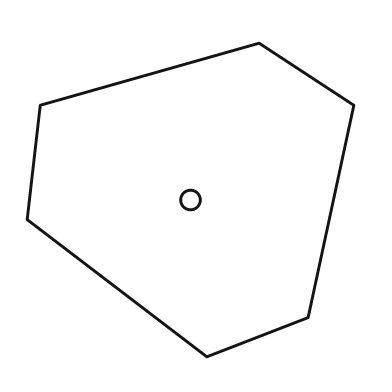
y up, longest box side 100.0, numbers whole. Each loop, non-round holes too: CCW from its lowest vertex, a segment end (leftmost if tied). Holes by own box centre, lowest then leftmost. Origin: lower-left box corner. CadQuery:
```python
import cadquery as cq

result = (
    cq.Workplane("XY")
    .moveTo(55.0, 0.0)
    .lineTo(86.0, 12.0)
    .lineTo(100.0, 77.0)
    .lineTo(71.0, 96.0)
    .lineTo(4.0, 77.0)
    .lineTo(0.0, 42.0)
    .close()
    .moveTo(50.0, 48.0)
    .circle(3.0)
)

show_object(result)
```